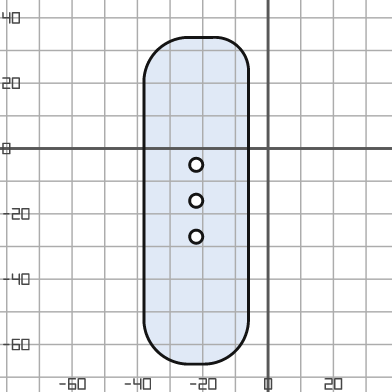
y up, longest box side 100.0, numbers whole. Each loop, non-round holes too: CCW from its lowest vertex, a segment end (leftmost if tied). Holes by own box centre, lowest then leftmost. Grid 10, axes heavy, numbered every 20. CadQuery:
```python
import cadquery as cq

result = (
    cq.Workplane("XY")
    .moveTo(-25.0, -66.0)
    .lineTo(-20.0, -66.0)
    .threePointArc((-10.0, -62.0), (-6.0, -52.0))
    .lineTo(-6.0, 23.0)
    .threePointArc((-9.0, 31.0), (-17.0, 34.0))
    .lineTo(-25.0, 34.0)
    .threePointArc((-34.0, 30.0), (-38.0, 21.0))
    .lineTo(-38.0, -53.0)
    .threePointArc((-34.0, -62.0), (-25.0, -66.0))
    .close()
    .moveTo(-22.0, -27.0)
    .circle(2.0)
    .moveTo(-22.0, -16.0)
    .circle(2.0)
    .moveTo(-22.0, -5.0)
    .circle(2.0)
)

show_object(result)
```